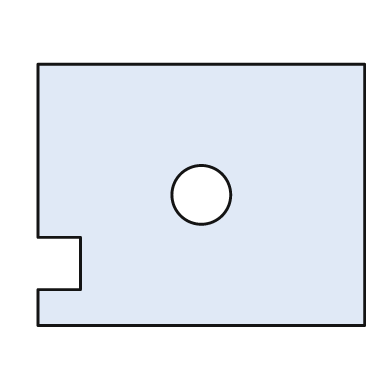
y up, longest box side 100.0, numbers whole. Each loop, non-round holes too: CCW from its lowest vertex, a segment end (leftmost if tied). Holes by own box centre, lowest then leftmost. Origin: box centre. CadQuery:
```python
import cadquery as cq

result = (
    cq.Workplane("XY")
    .moveTo(-50.0, -40.0)
    .lineTo(50.0, -40.0)
    .lineTo(50.0, 40.0)
    .lineTo(-50.0, 40.0)
    .lineTo(-50.0, -13.0)
    .lineTo(-37.0, -13.0)
    .lineTo(-37.0, -29.0)
    .lineTo(-50.0, -29.0)
    .close()
    .moveTo(0.0, 0.0)
    .circle(9.0)
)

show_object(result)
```